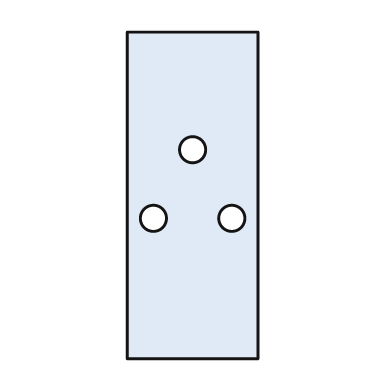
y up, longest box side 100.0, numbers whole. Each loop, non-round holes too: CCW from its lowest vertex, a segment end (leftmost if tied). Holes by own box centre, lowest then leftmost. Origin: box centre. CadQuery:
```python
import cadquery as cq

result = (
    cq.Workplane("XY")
    .moveTo(-20.0, -50.0)
    .lineTo(20.0, -50.0)
    .lineTo(20.0, 50.0)
    .lineTo(-20.0, 50.0)
    .close()
    .moveTo(-12.0, -7.0)
    .circle(4.0)
    .moveTo(12.0, -7.0)
    .circle(4.0)
    .moveTo(0.0, 14.0)
    .circle(4.0)
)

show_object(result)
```